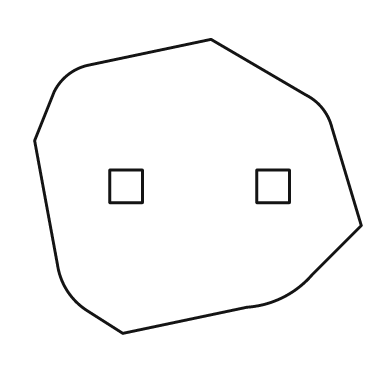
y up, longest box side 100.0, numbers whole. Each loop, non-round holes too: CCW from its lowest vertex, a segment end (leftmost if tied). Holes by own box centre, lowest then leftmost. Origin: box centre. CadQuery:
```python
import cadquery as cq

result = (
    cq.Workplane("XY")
    .moveTo(-23.0, -45.0)
    .lineTo(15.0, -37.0)
    .threePointArc((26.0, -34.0), (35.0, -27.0))
    .lineTo(50.0, -12.0)
    .lineTo(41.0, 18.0)
    .threePointArc((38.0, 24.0), (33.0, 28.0))
    .lineTo(4.0, 45.0)
    .lineTo(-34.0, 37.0)
    .threePointArc((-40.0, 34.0), (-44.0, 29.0))
    .lineTo(-50.0, 14.0)
    .lineTo(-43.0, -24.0)
    .threePointArc((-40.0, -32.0), (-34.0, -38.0))
    .close()
    .moveTo(-27.0, -5.0)
    .lineTo(-17.0, -5.0)
    .lineTo(-17.0, 5.0)
    .lineTo(-27.0, 5.0)
    .close()
    .moveTo(18.0, -5.0)
    .lineTo(28.0, -5.0)
    .lineTo(28.0, 5.0)
    .lineTo(18.0, 5.0)
    .close()
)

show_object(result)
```